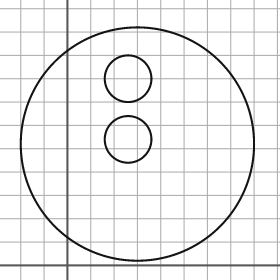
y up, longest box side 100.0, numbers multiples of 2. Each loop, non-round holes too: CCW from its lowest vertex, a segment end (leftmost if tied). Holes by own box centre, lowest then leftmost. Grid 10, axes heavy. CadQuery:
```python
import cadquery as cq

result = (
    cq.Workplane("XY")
    .moveTo(30.0, 52.0)
    .circle(50.0)
    .moveTo(26.0, 54.0)
    .circle(10.0)
    .moveTo(26.0, 80.0)
    .circle(10.0)
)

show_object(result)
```